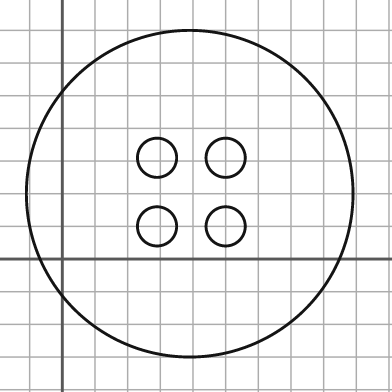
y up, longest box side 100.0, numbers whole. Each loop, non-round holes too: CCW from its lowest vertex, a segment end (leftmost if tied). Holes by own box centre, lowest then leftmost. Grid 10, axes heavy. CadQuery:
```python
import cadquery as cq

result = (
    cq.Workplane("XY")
    .moveTo(39.0, 20.0)
    .circle(50.0)
    .moveTo(29.0, 10.0)
    .circle(6.0)
    .moveTo(50.0, 10.0)
    .circle(6.0)
    .moveTo(29.0, 31.0)
    .circle(6.0)
    .moveTo(50.0, 31.0)
    .circle(6.0)
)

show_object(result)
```